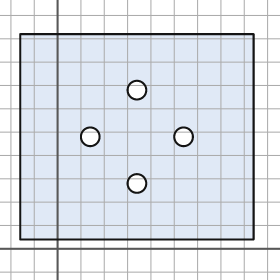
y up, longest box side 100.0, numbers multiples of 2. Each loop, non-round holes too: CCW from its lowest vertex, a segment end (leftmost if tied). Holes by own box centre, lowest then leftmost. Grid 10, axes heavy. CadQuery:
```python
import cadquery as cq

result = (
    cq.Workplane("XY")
    .moveTo(-16.0, 4.0)
    .lineTo(84.0, 4.0)
    .lineTo(84.0, 92.0)
    .lineTo(-16.0, 92.0)
    .close()
    .moveTo(34.0, 28.0)
    .circle(4.0)
    .moveTo(14.0, 48.0)
    .circle(4.0)
    .moveTo(54.0, 48.0)
    .circle(4.0)
    .moveTo(34.0, 68.0)
    .circle(4.0)
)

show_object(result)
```